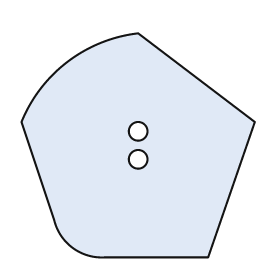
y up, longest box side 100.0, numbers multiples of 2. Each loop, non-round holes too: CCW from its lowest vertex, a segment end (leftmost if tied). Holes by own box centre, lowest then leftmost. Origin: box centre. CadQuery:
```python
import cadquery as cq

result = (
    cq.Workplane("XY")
    .moveTo(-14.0, -48.0)
    .lineTo(30.0, -48.0)
    .lineTo(50.0, 10.0)
    .lineTo(0.0, 48.0)
    .threePointArc((-30.0, 36.0), (-50.0, 10.0))
    .lineTo(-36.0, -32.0)
    .threePointArc((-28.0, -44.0), (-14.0, -48.0))
    .close()
    .moveTo(0.0, -6.0)
    .circle(4.0)
    .moveTo(0.0, 6.0)
    .circle(4.0)
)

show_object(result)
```